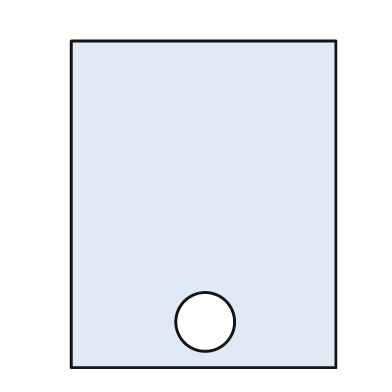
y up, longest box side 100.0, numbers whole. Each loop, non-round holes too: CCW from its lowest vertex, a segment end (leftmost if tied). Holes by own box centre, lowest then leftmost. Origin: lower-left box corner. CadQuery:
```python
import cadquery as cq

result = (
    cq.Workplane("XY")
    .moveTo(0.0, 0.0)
    .lineTo(81.0, 0.0)
    .lineTo(81.0, 100.0)
    .lineTo(0.0, 100.0)
    .close()
    .moveTo(41.0, 14.0)
    .circle(9.0)
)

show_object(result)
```